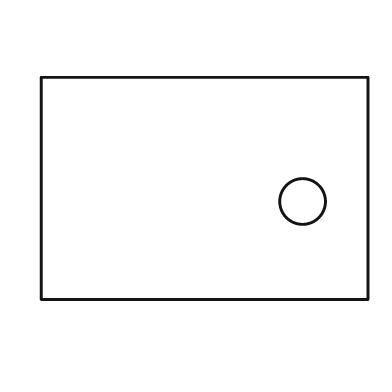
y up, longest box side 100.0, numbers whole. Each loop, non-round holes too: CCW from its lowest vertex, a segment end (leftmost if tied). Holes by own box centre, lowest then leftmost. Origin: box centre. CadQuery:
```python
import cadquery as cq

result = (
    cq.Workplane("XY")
    .moveTo(-50.0, -34.0)
    .lineTo(50.0, -34.0)
    .lineTo(50.0, 34.0)
    .lineTo(-50.0, 34.0)
    .close()
    .moveTo(30.0, -4.0)
    .circle(7.0)
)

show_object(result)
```